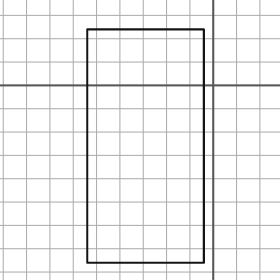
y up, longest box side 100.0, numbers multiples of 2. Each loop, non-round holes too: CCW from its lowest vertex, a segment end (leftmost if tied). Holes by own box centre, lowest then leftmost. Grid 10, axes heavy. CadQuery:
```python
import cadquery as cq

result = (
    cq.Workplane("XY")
    .moveTo(-54.0, -76.0)
    .lineTo(-4.0, -76.0)
    .lineTo(-4.0, 24.0)
    .lineTo(-54.0, 24.0)
    .close()
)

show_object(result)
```